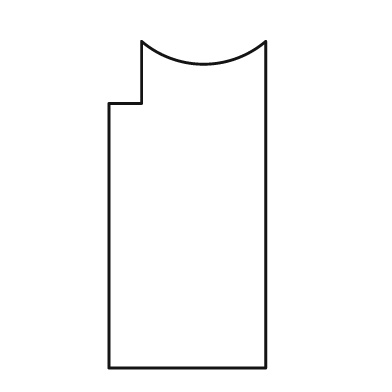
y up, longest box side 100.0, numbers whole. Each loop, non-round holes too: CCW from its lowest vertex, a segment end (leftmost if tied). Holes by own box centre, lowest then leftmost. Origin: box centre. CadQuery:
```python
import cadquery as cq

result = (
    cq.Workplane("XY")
    .moveTo(-24.0, -50.0)
    .lineTo(24.0, -50.0)
    .lineTo(24.0, 50.0)
    .threePointArc((5.0, 43.0), (-14.0, 50.0))
    .lineTo(-14.0, 31.0)
    .lineTo(-24.0, 31.0)
    .close()
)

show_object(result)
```